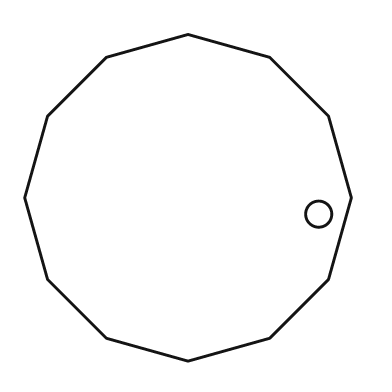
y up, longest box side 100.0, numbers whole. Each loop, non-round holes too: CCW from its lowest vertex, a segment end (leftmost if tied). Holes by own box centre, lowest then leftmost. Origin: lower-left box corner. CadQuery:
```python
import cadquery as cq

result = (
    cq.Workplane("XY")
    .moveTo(50.0, 0.0)
    .lineTo(75.0, 7.0)
    .lineTo(93.0, 25.0)
    .lineTo(100.0, 50.0)
    .lineTo(93.0, 75.0)
    .lineTo(75.0, 93.0)
    .lineTo(50.0, 100.0)
    .lineTo(25.0, 93.0)
    .lineTo(7.0, 75.0)
    .lineTo(0.0, 50.0)
    .lineTo(7.0, 25.0)
    .lineTo(25.0, 7.0)
    .close()
    .moveTo(90.0, 45.0)
    .circle(4.0)
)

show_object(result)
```